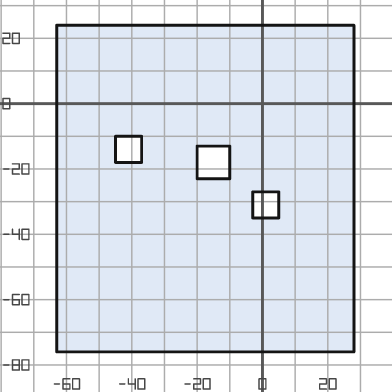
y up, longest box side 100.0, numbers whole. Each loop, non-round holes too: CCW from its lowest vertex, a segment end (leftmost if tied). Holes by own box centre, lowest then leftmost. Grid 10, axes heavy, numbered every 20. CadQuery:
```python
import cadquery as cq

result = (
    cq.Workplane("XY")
    .moveTo(-63.0, -76.0)
    .lineTo(28.0, -76.0)
    .lineTo(28.0, 24.0)
    .lineTo(-63.0, 24.0)
    .close()
    .moveTo(-3.0, -35.0)
    .lineTo(5.0, -35.0)
    .lineTo(5.0, -27.0)
    .lineTo(-3.0, -27.0)
    .close()
    .moveTo(-20.0, -23.0)
    .lineTo(-10.0, -23.0)
    .lineTo(-10.0, -13.0)
    .lineTo(-20.0, -13.0)
    .close()
    .moveTo(-45.0, -18.0)
    .lineTo(-37.0, -18.0)
    .lineTo(-37.0, -10.0)
    .lineTo(-45.0, -10.0)
    .close()
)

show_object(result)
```